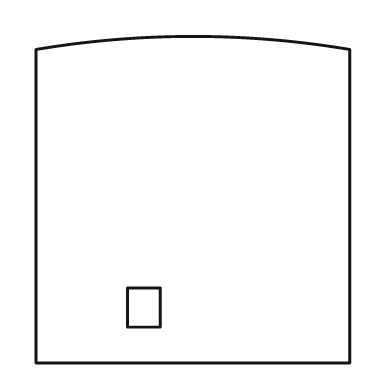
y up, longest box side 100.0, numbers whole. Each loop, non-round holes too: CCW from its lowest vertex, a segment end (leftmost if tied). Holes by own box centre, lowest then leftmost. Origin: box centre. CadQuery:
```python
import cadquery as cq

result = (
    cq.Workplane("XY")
    .moveTo(-48.0, -50.0)
    .lineTo(48.0, -50.0)
    .lineTo(48.0, 46.0)
    .threePointArc((0.0, 50.0), (-48.0, 46.0))
    .close()
    .moveTo(-20.0, -39.0)
    .lineTo(-10.0, -39.0)
    .lineTo(-10.0, -27.0)
    .lineTo(-20.0, -27.0)
    .close()
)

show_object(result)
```